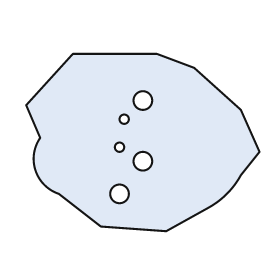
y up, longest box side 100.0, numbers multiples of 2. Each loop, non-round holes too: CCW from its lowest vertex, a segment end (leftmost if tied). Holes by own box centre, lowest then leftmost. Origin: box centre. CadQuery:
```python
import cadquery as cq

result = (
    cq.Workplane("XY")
    .moveTo(10.0, -38.0)
    .lineTo(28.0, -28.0)
    .threePointArc((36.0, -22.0), (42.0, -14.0))
    .lineTo(50.0, -4.0)
    .lineTo(42.0, 14.0)
    .lineTo(22.0, 32.0)
    .lineTo(6.0, 38.0)
    .lineTo(-30.0, 38.0)
    .lineTo(-50.0, 16.0)
    .lineTo(-44.0, 2.0)
    .threePointArc((-46.0, -12.0), (-36.0, -22.0))
    .lineTo(-18.0, -36.0)
    .close()
    .moveTo(-10.0, -22.0)
    .circle(4.0)
    .moveTo(0.0, -8.0)
    .circle(4.0)
    .moveTo(-10.0, -2.0)
    .circle(2.0)
    .moveTo(-8.0, 10.0)
    .circle(2.0)
    .moveTo(0.0, 18.0)
    .circle(4.0)
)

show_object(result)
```